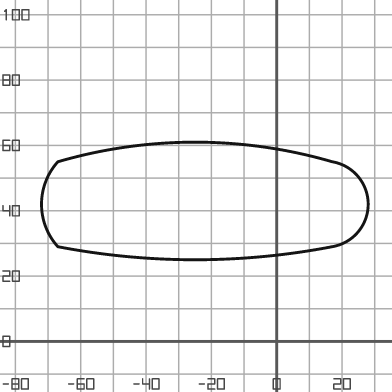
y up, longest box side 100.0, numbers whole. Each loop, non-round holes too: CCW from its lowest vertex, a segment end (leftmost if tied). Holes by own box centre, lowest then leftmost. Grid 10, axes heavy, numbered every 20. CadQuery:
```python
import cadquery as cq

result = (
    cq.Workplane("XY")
    .moveTo(-67.0, 29.0)
    .threePointArc((-25.0, 25.0), (17.0, 29.0))
    .threePointArc((28.0, 42.0), (17.0, 55.0))
    .threePointArc((-25.0, 61.0), (-67.0, 55.0))
    .threePointArc((-72.0, 42.0), (-67.0, 29.0))
    .close()
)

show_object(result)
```